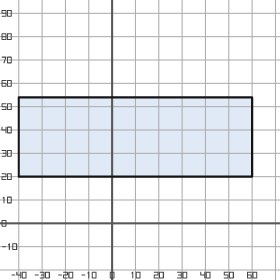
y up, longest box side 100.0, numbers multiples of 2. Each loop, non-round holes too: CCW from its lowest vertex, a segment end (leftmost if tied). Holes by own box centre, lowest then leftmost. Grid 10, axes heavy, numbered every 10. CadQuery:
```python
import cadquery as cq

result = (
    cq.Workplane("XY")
    .moveTo(-40.0, 20.0)
    .lineTo(60.0, 20.0)
    .lineTo(60.0, 54.0)
    .lineTo(-40.0, 54.0)
    .close()
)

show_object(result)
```